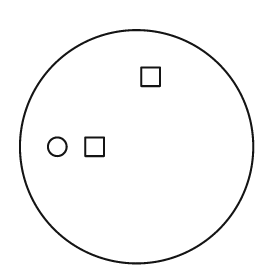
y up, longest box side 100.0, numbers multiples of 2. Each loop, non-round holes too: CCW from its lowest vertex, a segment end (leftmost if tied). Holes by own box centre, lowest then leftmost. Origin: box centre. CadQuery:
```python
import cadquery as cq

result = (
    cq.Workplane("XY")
    .moveTo(0.0, 0.0)
    .circle(50.0)
    .moveTo(-34.0, 0.0)
    .circle(4.0)
    .moveTo(-22.0, -4.0)
    .lineTo(-14.0, -4.0)
    .lineTo(-14.0, 4.0)
    .lineTo(-22.0, 4.0)
    .close()
    .moveTo(2.0, 26.0)
    .lineTo(10.0, 26.0)
    .lineTo(10.0, 34.0)
    .lineTo(2.0, 34.0)
    .close()
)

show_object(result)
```